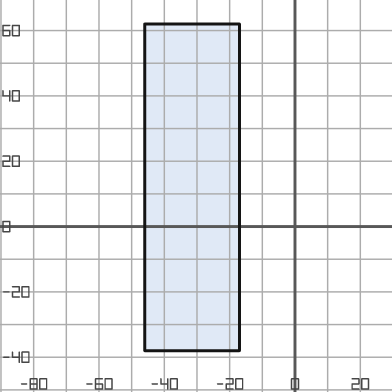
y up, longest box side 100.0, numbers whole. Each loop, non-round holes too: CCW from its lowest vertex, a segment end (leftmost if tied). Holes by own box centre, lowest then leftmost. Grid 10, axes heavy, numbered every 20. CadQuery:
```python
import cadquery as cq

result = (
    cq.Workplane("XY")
    .moveTo(-46.0, -38.0)
    .lineTo(-17.0, -38.0)
    .lineTo(-17.0, 62.0)
    .lineTo(-46.0, 62.0)
    .close()
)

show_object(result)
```